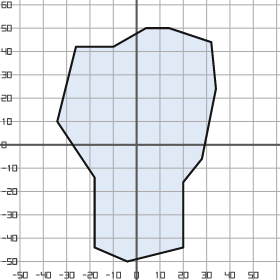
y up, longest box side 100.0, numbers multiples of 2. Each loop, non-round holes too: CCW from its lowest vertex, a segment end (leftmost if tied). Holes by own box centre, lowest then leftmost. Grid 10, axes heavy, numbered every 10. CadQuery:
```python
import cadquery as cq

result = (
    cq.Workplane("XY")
    .moveTo(-4.0, -50.0)
    .lineTo(20.0, -44.0)
    .lineTo(20.0, -16.0)
    .lineTo(28.0, -6.0)
    .lineTo(34.0, 24.0)
    .lineTo(32.0, 44.0)
    .lineTo(14.0, 50.0)
    .lineTo(4.0, 50.0)
    .lineTo(-10.0, 42.0)
    .lineTo(-26.0, 42.0)
    .lineTo(-34.0, 10.0)
    .lineTo(-18.0, -14.0)
    .lineTo(-18.0, -44.0)
    .close()
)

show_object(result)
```